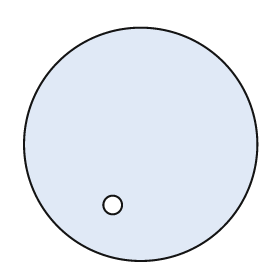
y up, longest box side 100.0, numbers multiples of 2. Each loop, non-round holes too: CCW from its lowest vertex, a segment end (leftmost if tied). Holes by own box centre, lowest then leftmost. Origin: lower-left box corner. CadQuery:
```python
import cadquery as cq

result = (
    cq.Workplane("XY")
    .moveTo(50.0, 50.0)
    .circle(50.0)
    .moveTo(38.0, 24.0)
    .circle(4.0)
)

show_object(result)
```